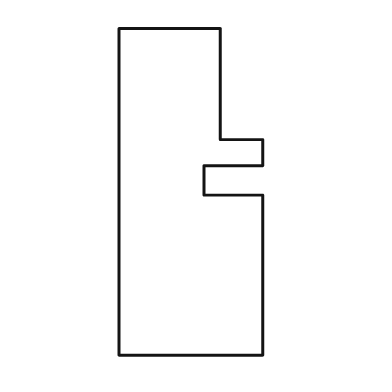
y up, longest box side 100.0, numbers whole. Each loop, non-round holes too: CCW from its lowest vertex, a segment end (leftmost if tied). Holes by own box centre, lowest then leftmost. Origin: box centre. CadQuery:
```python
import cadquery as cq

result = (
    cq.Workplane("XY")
    .moveTo(-22.0, -50.0)
    .lineTo(22.0, -50.0)
    .lineTo(22.0, -1.0)
    .lineTo(4.0, -1.0)
    .lineTo(4.0, 8.0)
    .lineTo(22.0, 8.0)
    .lineTo(22.0, 16.0)
    .lineTo(9.0, 16.0)
    .lineTo(9.0, 50.0)
    .lineTo(-22.0, 50.0)
    .close()
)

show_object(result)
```